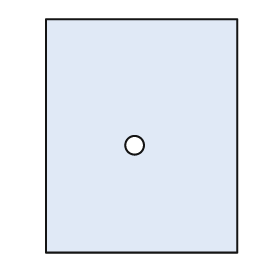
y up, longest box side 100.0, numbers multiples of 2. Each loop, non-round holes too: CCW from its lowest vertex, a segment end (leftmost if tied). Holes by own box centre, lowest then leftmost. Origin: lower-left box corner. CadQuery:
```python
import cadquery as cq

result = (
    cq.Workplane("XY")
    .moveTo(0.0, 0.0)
    .lineTo(82.0, 0.0)
    .lineTo(82.0, 100.0)
    .lineTo(0.0, 100.0)
    .close()
    .moveTo(38.0, 46.0)
    .circle(4.0)
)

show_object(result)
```